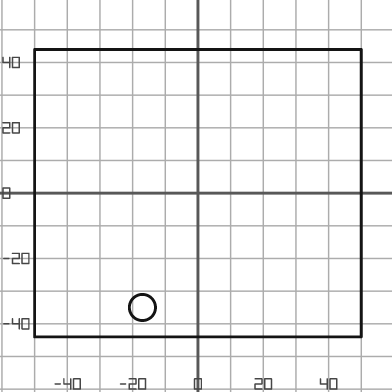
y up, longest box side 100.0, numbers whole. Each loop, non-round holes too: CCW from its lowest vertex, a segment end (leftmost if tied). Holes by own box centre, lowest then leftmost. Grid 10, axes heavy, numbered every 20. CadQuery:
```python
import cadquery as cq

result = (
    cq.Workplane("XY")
    .moveTo(-50.0, -44.0)
    .lineTo(50.0, -44.0)
    .lineTo(50.0, 44.0)
    .lineTo(-50.0, 44.0)
    .close()
    .moveTo(-17.0, -35.0)
    .circle(4.0)
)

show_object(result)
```